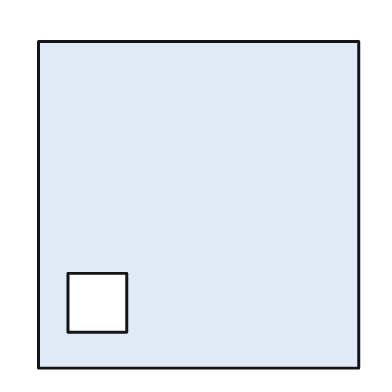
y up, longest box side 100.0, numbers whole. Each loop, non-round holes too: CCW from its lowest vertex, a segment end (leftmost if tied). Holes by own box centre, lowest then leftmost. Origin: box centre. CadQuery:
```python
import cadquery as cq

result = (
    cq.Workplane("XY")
    .moveTo(-49.0, -50.0)
    .lineTo(49.0, -50.0)
    .lineTo(49.0, 50.0)
    .lineTo(-49.0, 50.0)
    .close()
    .moveTo(-40.0, -39.0)
    .lineTo(-22.0, -39.0)
    .lineTo(-22.0, -21.0)
    .lineTo(-40.0, -21.0)
    .close()
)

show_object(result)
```